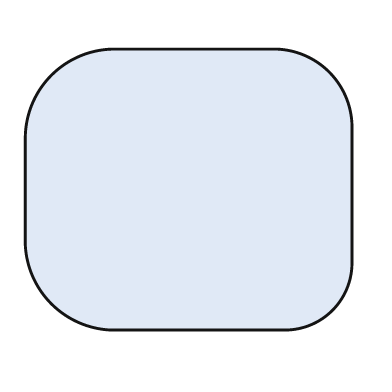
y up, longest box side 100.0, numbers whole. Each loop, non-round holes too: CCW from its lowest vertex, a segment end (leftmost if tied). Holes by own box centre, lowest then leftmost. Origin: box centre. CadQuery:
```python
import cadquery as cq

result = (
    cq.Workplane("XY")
    .moveTo(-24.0, -43.0)
    .lineTo(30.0, -43.0)
    .threePointArc((44.0, -37.0), (50.0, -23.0))
    .lineTo(50.0, 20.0)
    .threePointArc((43.0, 36.0), (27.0, 43.0))
    .lineTo(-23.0, 43.0)
    .threePointArc((-42.0, 35.0), (-50.0, 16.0))
    .lineTo(-50.0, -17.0)
    .threePointArc((-42.0, -35.0), (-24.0, -43.0))
    .close()
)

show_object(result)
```